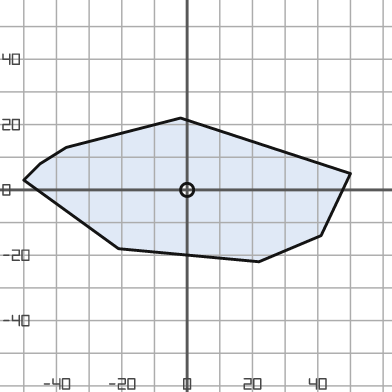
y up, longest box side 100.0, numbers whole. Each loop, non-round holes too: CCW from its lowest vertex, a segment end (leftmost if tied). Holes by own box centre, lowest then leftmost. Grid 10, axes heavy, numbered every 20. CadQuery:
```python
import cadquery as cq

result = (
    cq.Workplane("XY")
    .moveTo(22.0, -22.0)
    .lineTo(41.0, -14.0)
    .lineTo(50.0, 5.0)
    .lineTo(-2.0, 22.0)
    .lineTo(-37.0, 13.0)
    .lineTo(-45.0, 8.0)
    .lineTo(-50.0, 3.0)
    .lineTo(-21.0, -18.0)
    .close()
    .moveTo(0.0, 0.0)
    .circle(2.0)
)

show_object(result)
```